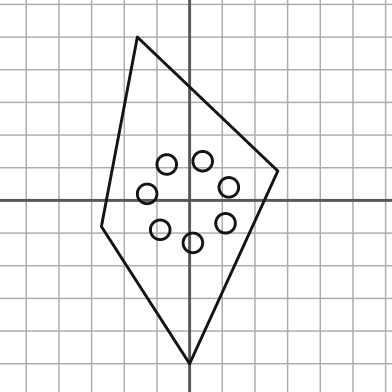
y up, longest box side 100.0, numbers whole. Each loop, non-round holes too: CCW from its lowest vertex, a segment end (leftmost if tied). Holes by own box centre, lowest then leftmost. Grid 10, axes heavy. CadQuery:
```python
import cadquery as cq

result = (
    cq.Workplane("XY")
    .moveTo(0.0, -50.0)
    .lineTo(27.0, 9.0)
    .lineTo(-16.0, 50.0)
    .lineTo(-27.0, -8.0)
    .close()
    .moveTo(1.0, -13.0)
    .circle(3.0)
    .moveTo(-9.0, -9.0)
    .circle(3.0)
    .moveTo(11.0, -7.0)
    .circle(3.0)
    .moveTo(-13.0, 2.0)
    .circle(3.0)
    .moveTo(12.0, 4.0)
    .circle(3.0)
    .moveTo(-7.0, 11.0)
    .circle(3.0)
    .moveTo(4.0, 12.0)
    .circle(3.0)
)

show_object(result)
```